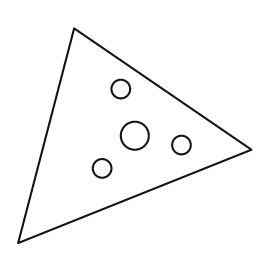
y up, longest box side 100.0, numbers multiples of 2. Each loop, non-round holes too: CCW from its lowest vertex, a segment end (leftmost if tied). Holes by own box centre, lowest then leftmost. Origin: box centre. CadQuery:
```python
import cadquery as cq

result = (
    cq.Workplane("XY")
    .moveTo(-50.0, -46.0)
    .lineTo(50.0, -6.0)
    .lineTo(-26.0, 46.0)
    .close()
    .moveTo(-14.0, -14.0)
    .circle(4.0)
    .moveTo(20.0, -4.0)
    .circle(4.0)
    .moveTo(0.0, 0.0)
    .circle(6.0)
    .moveTo(-6.0, 20.0)
    .circle(4.0)
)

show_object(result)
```